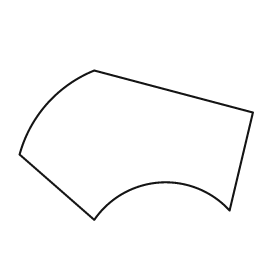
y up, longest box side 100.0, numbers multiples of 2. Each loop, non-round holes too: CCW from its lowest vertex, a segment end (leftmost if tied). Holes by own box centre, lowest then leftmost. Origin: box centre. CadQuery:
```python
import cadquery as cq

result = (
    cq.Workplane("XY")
    .moveTo(-18.0, -32.0)
    .threePointArc((10.0, -16.0), (40.0, -28.0))
    .lineTo(50.0, 14.0)
    .lineTo(-18.0, 32.0)
    .threePointArc((-38.0, 18.0), (-50.0, -4.0))
    .close()
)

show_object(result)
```